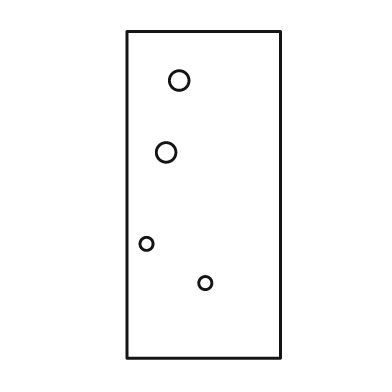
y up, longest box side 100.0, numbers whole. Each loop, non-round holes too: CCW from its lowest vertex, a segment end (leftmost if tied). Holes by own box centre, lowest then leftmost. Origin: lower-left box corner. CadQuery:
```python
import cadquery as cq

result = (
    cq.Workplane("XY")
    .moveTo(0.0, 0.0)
    .lineTo(47.0, 0.0)
    .lineTo(47.0, 100.0)
    .lineTo(0.0, 100.0)
    .close()
    .moveTo(24.0, 23.0)
    .circle(2.0)
    .moveTo(6.0, 35.0)
    .circle(2.0)
    .moveTo(12.0, 63.0)
    .circle(3.0)
    .moveTo(16.0, 85.0)
    .circle(3.0)
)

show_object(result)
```